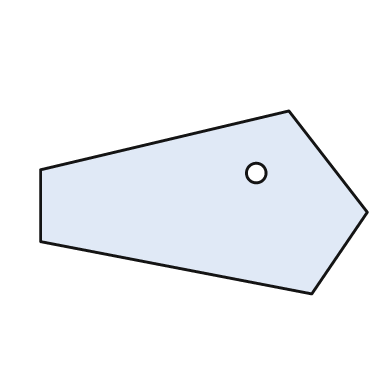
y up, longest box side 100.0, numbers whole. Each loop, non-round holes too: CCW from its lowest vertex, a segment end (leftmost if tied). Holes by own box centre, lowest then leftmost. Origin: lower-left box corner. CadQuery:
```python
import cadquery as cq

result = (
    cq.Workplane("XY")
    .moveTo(83.0, 0.0)
    .lineTo(100.0, 25.0)
    .lineTo(76.0, 56.0)
    .lineTo(0.0, 38.0)
    .lineTo(0.0, 16.0)
    .close()
    .moveTo(66.0, 37.0)
    .circle(3.0)
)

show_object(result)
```